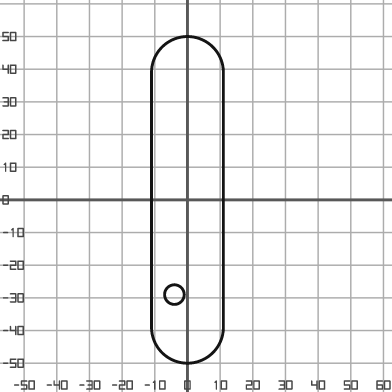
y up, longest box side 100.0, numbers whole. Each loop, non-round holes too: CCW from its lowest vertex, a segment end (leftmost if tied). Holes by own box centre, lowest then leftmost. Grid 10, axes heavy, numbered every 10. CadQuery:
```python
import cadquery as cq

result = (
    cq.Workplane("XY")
    .moveTo(-11.0, -39.0)
    .threePointArc((0.0, -50.0), (11.0, -39.0))
    .lineTo(11.0, 39.0)
    .threePointArc((0.0, 50.0), (-11.0, 39.0))
    .close()
    .moveTo(-4.0, -29.0)
    .circle(3.0)
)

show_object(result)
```